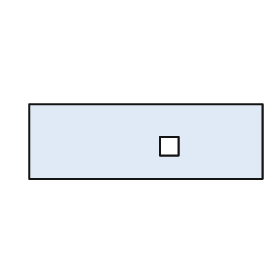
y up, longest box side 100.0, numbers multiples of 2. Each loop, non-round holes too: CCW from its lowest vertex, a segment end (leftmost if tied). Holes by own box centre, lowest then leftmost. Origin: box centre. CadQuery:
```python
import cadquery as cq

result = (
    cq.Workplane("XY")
    .moveTo(-50.0, -16.0)
    .lineTo(50.0, -16.0)
    .lineTo(50.0, 16.0)
    .lineTo(-50.0, 16.0)
    .close()
    .moveTo(6.0, -6.0)
    .lineTo(14.0, -6.0)
    .lineTo(14.0, 2.0)
    .lineTo(6.0, 2.0)
    .close()
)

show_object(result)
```